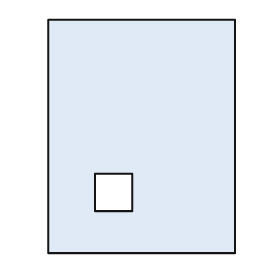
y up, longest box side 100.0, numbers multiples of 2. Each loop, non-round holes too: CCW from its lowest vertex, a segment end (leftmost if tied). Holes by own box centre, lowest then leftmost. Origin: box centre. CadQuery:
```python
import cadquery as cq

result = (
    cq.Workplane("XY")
    .moveTo(-40.0, -50.0)
    .lineTo(40.0, -50.0)
    .lineTo(40.0, 50.0)
    .lineTo(-40.0, 50.0)
    .close()
    .moveTo(-20.0, -32.0)
    .lineTo(-4.0, -32.0)
    .lineTo(-4.0, -16.0)
    .lineTo(-20.0, -16.0)
    .close()
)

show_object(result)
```